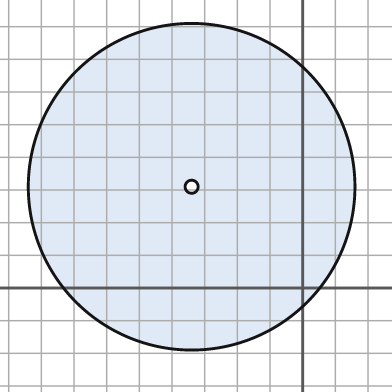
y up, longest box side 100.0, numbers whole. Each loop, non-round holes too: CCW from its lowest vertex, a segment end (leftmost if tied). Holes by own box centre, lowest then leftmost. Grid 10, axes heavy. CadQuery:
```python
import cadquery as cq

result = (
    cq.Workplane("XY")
    .moveTo(-34.0, 31.0)
    .circle(50.0)
    .moveTo(-34.0, 31.0)
    .circle(2.0)
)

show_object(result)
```